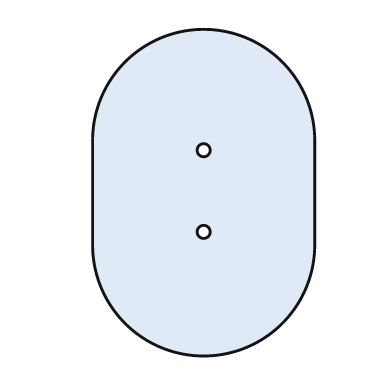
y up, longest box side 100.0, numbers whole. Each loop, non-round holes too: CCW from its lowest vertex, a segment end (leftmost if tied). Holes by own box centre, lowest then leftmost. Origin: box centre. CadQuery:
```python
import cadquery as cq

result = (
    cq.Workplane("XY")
    .moveTo(-34.0, -16.0)
    .threePointArc((0.0, -50.0), (34.0, -16.0))
    .lineTo(34.0, 16.0)
    .threePointArc((0.0, 50.0), (-34.0, 16.0))
    .close()
    .moveTo(0.0, -12.0)
    .circle(2.0)
    .moveTo(0.0, 13.0)
    .circle(2.0)
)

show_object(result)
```